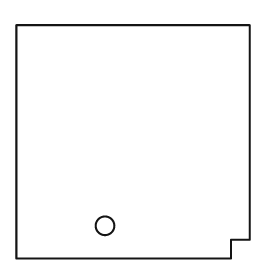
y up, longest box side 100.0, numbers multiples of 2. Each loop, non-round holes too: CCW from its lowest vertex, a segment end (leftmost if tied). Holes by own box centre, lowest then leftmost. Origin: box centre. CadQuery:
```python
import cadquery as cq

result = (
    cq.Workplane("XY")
    .moveTo(-50.0, -50.0)
    .lineTo(42.0, -50.0)
    .lineTo(42.0, -42.0)
    .lineTo(50.0, -42.0)
    .lineTo(50.0, 50.0)
    .lineTo(-50.0, 50.0)
    .close()
    .moveTo(-12.0, -36.0)
    .circle(4.0)
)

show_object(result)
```